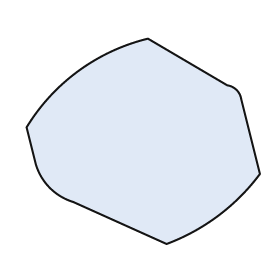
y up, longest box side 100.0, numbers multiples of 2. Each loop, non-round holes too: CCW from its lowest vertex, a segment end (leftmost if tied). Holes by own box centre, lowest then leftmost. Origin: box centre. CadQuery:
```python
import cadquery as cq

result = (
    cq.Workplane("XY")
    .moveTo(10.0, -44.0)
    .threePointArc((32.0, -32.0), (50.0, -14.0))
    .lineTo(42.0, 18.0)
    .threePointArc((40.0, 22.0), (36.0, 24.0))
    .lineTo(2.0, 44.0)
    .threePointArc((-28.0, 30.0), (-50.0, 6.0))
    .lineTo(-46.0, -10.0)
    .threePointArc((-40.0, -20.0), (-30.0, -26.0))
    .close()
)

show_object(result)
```